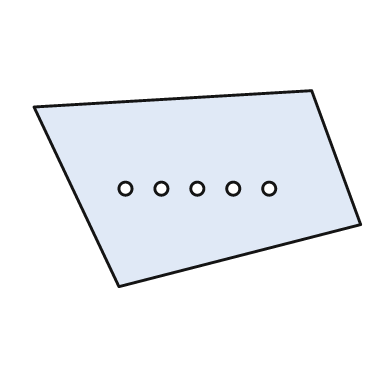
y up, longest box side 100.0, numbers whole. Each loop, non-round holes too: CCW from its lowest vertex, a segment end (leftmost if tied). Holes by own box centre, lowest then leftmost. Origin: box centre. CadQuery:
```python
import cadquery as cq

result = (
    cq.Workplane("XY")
    .moveTo(-24.0, -30.0)
    .lineTo(50.0, -11.0)
    .lineTo(35.0, 30.0)
    .lineTo(-50.0, 25.0)
    .close()
    .moveTo(-22.0, 0.0)
    .circle(2.0)
    .moveTo(-11.0, 0.0)
    .circle(2.0)
    .moveTo(0.0, 0.0)
    .circle(2.0)
    .moveTo(11.0, 0.0)
    .circle(2.0)
    .moveTo(22.0, 0.0)
    .circle(2.0)
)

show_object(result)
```